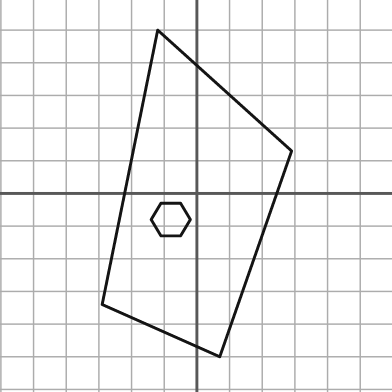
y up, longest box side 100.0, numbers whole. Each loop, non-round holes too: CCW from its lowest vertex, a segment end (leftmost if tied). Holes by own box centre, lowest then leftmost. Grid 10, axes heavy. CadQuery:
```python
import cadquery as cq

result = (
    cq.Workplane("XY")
    .moveTo(7.0, -50.0)
    .lineTo(29.0, 13.0)
    .lineTo(-12.0, 50.0)
    .lineTo(-29.0, -34.0)
    .close()
    .moveTo(-11.0, -13.0)
    .lineTo(-5.0, -13.0)
    .lineTo(-2.0, -8.0)
    .lineTo(-5.0, -3.0)
    .lineTo(-11.0, -3.0)
    .lineTo(-14.0, -8.0)
    .close()
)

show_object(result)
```